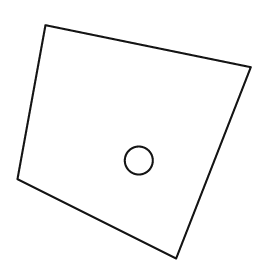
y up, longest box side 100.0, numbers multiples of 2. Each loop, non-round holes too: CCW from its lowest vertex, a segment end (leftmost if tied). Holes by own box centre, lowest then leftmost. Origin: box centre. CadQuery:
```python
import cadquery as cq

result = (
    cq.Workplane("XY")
    .moveTo(18.0, -50.0)
    .lineTo(50.0, 32.0)
    .lineTo(-38.0, 50.0)
    .lineTo(-50.0, -16.0)
    .close()
    .moveTo(2.0, -8.0)
    .circle(6.0)
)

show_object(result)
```